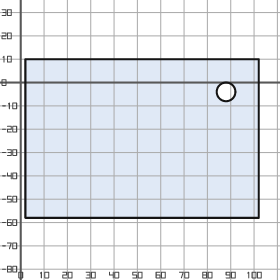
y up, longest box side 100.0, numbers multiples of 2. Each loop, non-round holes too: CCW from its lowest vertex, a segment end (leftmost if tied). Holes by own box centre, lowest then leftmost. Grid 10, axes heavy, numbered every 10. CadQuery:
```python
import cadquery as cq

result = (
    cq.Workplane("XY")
    .moveTo(2.0, -58.0)
    .lineTo(102.0, -58.0)
    .lineTo(102.0, 10.0)
    .lineTo(2.0, 10.0)
    .close()
    .moveTo(88.0, -4.0)
    .circle(4.0)
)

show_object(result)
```